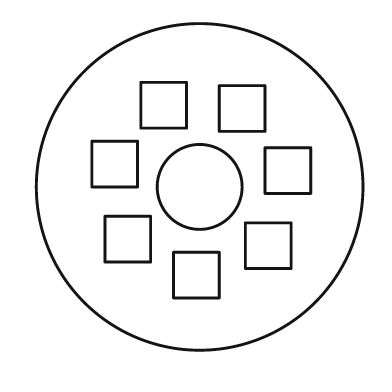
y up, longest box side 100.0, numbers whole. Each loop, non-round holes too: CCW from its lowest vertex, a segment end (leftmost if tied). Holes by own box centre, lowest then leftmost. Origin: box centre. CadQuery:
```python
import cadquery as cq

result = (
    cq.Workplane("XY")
    .moveTo(0.0, 0.0)
    .circle(50.0)
    .moveTo(-8.0, -34.0)
    .lineTo(6.0, -34.0)
    .lineTo(6.0, -20.0)
    .lineTo(-8.0, -20.0)
    .close()
    .moveTo(14.0, -25.0)
    .lineTo(28.0, -25.0)
    .lineTo(28.0, -11.0)
    .lineTo(14.0, -11.0)
    .close()
    .moveTo(-29.0, -23.0)
    .lineTo(-15.0, -23.0)
    .lineTo(-15.0, -9.0)
    .lineTo(-29.0, -9.0)
    .close()
    .moveTo(0.0, 0.0)
    .circle(13.0)
    .moveTo(20.0, -2.0)
    .lineTo(34.0, -2.0)
    .lineTo(34.0, 12.0)
    .lineTo(20.0, 12.0)
    .close()
    .moveTo(-33.0, 0.0)
    .lineTo(-19.0, 0.0)
    .lineTo(-19.0, 14.0)
    .lineTo(-33.0, 14.0)
    .close()
    .moveTo(6.0, 17.0)
    .lineTo(20.0, 17.0)
    .lineTo(20.0, 31.0)
    .lineTo(6.0, 31.0)
    .close()
    .moveTo(-18.0, 18.0)
    .lineTo(-4.0, 18.0)
    .lineTo(-4.0, 32.0)
    .lineTo(-18.0, 32.0)
    .close()
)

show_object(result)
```